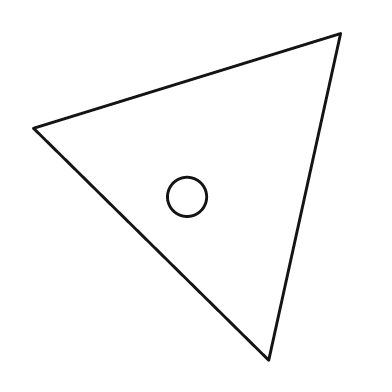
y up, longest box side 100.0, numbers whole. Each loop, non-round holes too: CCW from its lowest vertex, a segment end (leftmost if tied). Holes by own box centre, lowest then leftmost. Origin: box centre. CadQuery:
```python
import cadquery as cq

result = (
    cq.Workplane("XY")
    .moveTo(25.0, -50.0)
    .lineTo(47.0, 50.0)
    .lineTo(-47.0, 21.0)
    .close()
    .moveTo(0.0, 0.0)
    .circle(6.0)
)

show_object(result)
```